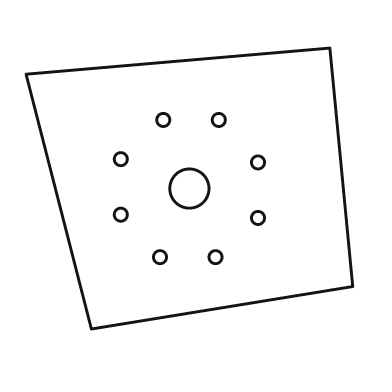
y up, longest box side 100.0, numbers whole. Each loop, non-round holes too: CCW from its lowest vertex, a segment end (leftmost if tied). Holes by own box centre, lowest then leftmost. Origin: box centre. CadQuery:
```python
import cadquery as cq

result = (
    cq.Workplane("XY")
    .moveTo(-30.0, -43.0)
    .lineTo(50.0, -30.0)
    .lineTo(43.0, 43.0)
    .lineTo(-50.0, 35.0)
    .close()
    .moveTo(-9.0, -21.0)
    .circle(2.0)
    .moveTo(8.0, -21.0)
    .circle(2.0)
    .moveTo(21.0, -9.0)
    .circle(2.0)
    .moveTo(-21.0, -8.0)
    .circle(2.0)
    .moveTo(0.0, 0.0)
    .circle(6.0)
    .moveTo(21.0, 8.0)
    .circle(2.0)
    .moveTo(-21.0, 9.0)
    .circle(2.0)
    .moveTo(-8.0, 21.0)
    .circle(2.0)
    .moveTo(9.0, 21.0)
    .circle(2.0)
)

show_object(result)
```